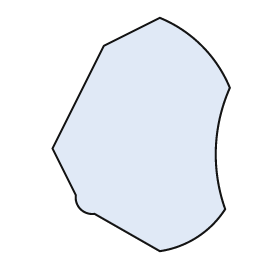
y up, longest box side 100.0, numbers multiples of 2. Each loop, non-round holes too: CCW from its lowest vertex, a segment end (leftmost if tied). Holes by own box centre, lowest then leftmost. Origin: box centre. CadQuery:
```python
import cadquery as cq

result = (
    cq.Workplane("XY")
    .moveTo(8.0, -50.0)
    .threePointArc((24.0, -44.0), (36.0, -32.0))
    .threePointArc((32.0, -6.0), (38.0, 20.0))
    .threePointArc((26.0, 38.0), (8.0, 50.0))
    .lineTo(-16.0, 38.0)
    .lineTo(-38.0, -6.0)
    .lineTo(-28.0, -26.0)
    .threePointArc((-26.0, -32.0), (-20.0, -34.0))
    .close()
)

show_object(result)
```